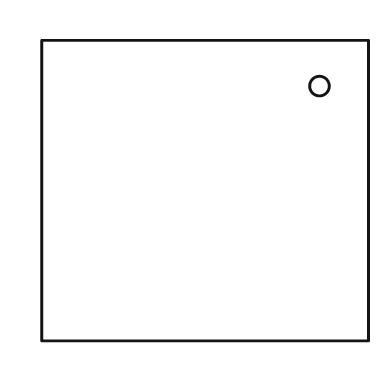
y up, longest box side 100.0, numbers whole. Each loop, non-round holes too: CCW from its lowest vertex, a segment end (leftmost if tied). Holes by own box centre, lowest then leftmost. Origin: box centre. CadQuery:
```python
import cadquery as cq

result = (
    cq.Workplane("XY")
    .moveTo(-50.0, -46.0)
    .lineTo(50.0, -46.0)
    .lineTo(50.0, 46.0)
    .lineTo(-50.0, 46.0)
    .close()
    .moveTo(35.0, 32.0)
    .circle(3.0)
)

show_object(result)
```